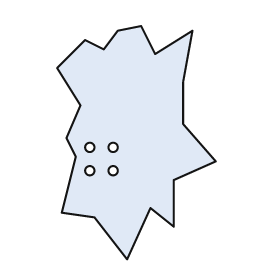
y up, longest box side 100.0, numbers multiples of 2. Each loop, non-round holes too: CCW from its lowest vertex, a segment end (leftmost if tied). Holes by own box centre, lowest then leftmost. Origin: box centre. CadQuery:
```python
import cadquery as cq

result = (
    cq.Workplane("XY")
    .moveTo(-4.0, -50.0)
    .lineTo(6.0, -28.0)
    .lineTo(16.0, -36.0)
    .lineTo(16.0, -16.0)
    .lineTo(34.0, -8.0)
    .lineTo(20.0, 8.0)
    .lineTo(20.0, 26.0)
    .lineTo(24.0, 48.0)
    .lineTo(8.0, 38.0)
    .lineTo(2.0, 50.0)
    .lineTo(-8.0, 48.0)
    .lineTo(-14.0, 40.0)
    .lineTo(-22.0, 44.0)
    .lineTo(-34.0, 32.0)
    .lineTo(-24.0, 16.0)
    .lineTo(-30.0, 2.0)
    .lineTo(-26.0, -6.0)
    .lineTo(-32.0, -30.0)
    .lineTo(-18.0, -32.0)
    .close()
    .moveTo(-20.0, -12.0)
    .circle(2.0)
    .moveTo(-10.0, -12.0)
    .circle(2.0)
    .moveTo(-20.0, -2.0)
    .circle(2.0)
    .moveTo(-10.0, -2.0)
    .circle(2.0)
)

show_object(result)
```